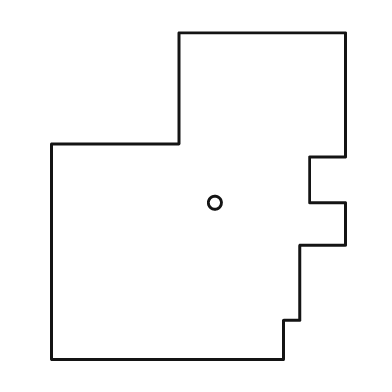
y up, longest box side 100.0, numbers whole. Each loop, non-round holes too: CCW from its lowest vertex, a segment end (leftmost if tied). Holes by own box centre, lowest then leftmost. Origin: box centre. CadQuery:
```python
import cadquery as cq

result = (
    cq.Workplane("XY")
    .moveTo(-45.0, -50.0)
    .lineTo(26.0, -50.0)
    .lineTo(26.0, -38.0)
    .lineTo(31.0, -38.0)
    .lineTo(31.0, -15.0)
    .lineTo(45.0, -15.0)
    .lineTo(45.0, -2.0)
    .lineTo(34.0, -2.0)
    .lineTo(34.0, 12.0)
    .lineTo(45.0, 12.0)
    .lineTo(45.0, 50.0)
    .lineTo(-6.0, 50.0)
    .lineTo(-6.0, 16.0)
    .lineTo(-45.0, 16.0)
    .close()
    .moveTo(5.0, -2.0)
    .circle(2.0)
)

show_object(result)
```